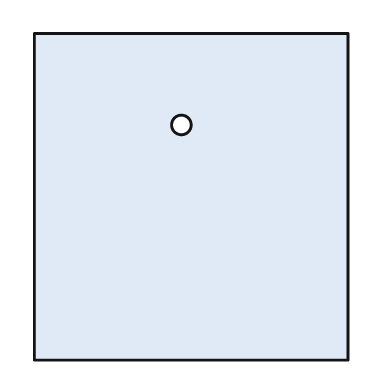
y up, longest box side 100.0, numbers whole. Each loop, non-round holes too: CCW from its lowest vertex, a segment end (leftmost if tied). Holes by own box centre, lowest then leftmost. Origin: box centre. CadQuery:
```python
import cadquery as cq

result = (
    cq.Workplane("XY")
    .moveTo(-48.0, -50.0)
    .lineTo(48.0, -50.0)
    .lineTo(48.0, 50.0)
    .lineTo(-48.0, 50.0)
    .close()
    .moveTo(-3.0, 22.0)
    .circle(3.0)
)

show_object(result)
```